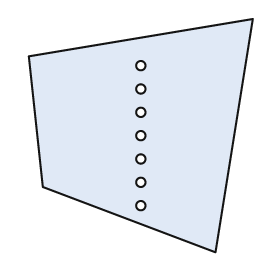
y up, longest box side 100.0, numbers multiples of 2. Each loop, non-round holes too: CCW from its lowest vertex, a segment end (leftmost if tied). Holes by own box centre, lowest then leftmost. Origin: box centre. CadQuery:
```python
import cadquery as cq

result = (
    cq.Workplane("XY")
    .moveTo(32.0, -50.0)
    .lineTo(48.0, 50.0)
    .lineTo(-48.0, 34.0)
    .lineTo(-42.0, -22.0)
    .close()
    .moveTo(0.0, -30.0)
    .circle(2.0)
    .moveTo(0.0, -20.0)
    .circle(2.0)
    .moveTo(0.0, -10.0)
    .circle(2.0)
    .moveTo(0.0, 0.0)
    .circle(2.0)
    .moveTo(0.0, 10.0)
    .circle(2.0)
    .moveTo(0.0, 20.0)
    .circle(2.0)
    .moveTo(0.0, 30.0)
    .circle(2.0)
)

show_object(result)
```